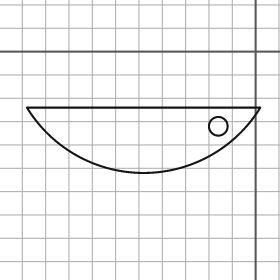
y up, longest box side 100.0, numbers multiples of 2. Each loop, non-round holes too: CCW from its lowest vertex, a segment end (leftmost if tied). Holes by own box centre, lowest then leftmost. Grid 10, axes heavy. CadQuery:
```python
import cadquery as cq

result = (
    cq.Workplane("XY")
    .moveTo(-98.0, -24.0)
    .threePointArc((-48.0, -52.0), (2.0, -24.0))
    .close()
    .moveTo(-16.0, -32.0)
    .circle(4.0)
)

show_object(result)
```